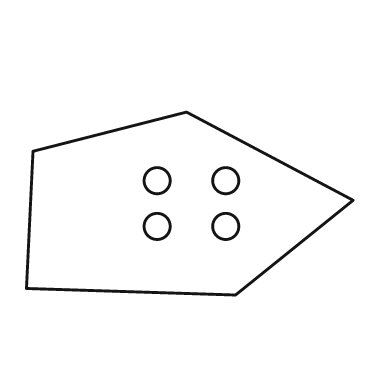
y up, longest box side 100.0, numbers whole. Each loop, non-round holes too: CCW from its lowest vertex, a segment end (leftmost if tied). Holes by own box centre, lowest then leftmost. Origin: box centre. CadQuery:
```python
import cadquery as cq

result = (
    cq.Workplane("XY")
    .moveTo(14.0, -28.0)
    .lineTo(50.0, 1.0)
    .lineTo(-1.0, 28.0)
    .lineTo(-48.0, 16.0)
    .lineTo(-50.0, -26.0)
    .close()
    .moveTo(-10.0, -7.0)
    .circle(4.0)
    .moveTo(11.0, -7.0)
    .circle(4.0)
    .moveTo(-10.0, 7.0)
    .circle(4.0)
    .moveTo(11.0, 7.0)
    .circle(4.0)
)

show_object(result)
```